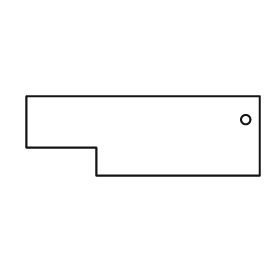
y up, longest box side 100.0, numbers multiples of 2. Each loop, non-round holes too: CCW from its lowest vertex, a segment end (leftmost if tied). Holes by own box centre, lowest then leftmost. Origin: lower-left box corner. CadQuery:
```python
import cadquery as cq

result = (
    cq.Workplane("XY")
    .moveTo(30.0, 0.0)
    .lineTo(100.0, 0.0)
    .lineTo(100.0, 34.0)
    .lineTo(0.0, 34.0)
    .lineTo(0.0, 12.0)
    .lineTo(30.0, 12.0)
    .close()
    .moveTo(94.0, 24.0)
    .circle(2.0)
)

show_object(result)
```